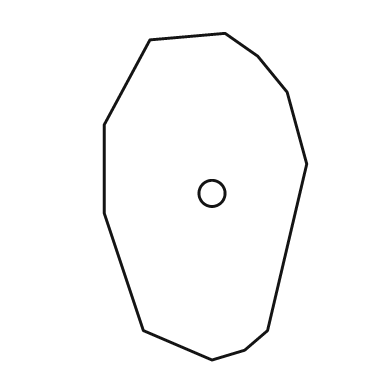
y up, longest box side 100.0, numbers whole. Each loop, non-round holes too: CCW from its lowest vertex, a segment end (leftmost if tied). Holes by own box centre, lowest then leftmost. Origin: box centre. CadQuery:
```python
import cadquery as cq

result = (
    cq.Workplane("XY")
    .moveTo(2.0, -50.0)
    .lineTo(12.0, -47.0)
    .lineTo(19.0, -41.0)
    .lineTo(31.0, 10.0)
    .lineTo(25.0, 32.0)
    .lineTo(16.0, 43.0)
    .lineTo(6.0, 50.0)
    .lineTo(-17.0, 48.0)
    .lineTo(-31.0, 22.0)
    .lineTo(-31.0, -5.0)
    .lineTo(-19.0, -41.0)
    .close()
    .moveTo(2.0, 1.0)
    .circle(4.0)
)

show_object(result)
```